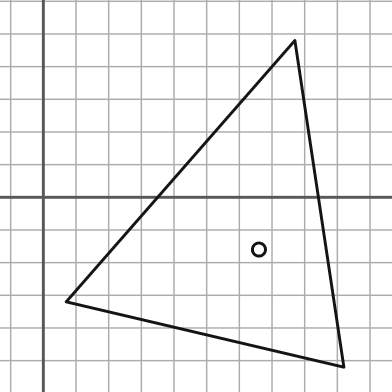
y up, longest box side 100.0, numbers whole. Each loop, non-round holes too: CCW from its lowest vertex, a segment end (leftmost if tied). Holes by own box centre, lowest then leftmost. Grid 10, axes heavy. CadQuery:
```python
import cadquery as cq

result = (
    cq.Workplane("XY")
    .moveTo(92.0, -52.0)
    .lineTo(77.0, 48.0)
    .lineTo(7.0, -32.0)
    .close()
    .moveTo(66.0, -16.0)
    .circle(2.0)
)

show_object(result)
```